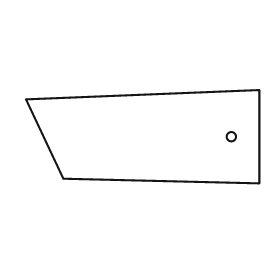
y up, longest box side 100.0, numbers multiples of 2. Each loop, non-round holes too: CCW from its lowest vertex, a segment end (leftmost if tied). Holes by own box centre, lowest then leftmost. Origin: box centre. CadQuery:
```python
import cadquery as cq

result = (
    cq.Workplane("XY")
    .moveTo(50.0, -20.0)
    .lineTo(50.0, 20.0)
    .lineTo(-50.0, 16.0)
    .lineTo(-34.0, -18.0)
    .close()
    .moveTo(38.0, 0.0)
    .circle(2.0)
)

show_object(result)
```